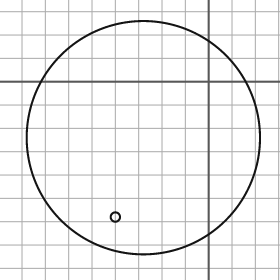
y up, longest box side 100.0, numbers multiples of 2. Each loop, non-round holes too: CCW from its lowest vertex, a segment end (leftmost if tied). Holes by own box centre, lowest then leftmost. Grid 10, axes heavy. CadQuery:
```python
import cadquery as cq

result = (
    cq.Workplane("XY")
    .moveTo(-28.0, -24.0)
    .circle(50.0)
    .moveTo(-40.0, -58.0)
    .circle(2.0)
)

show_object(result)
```